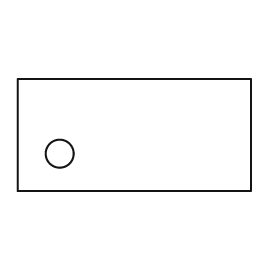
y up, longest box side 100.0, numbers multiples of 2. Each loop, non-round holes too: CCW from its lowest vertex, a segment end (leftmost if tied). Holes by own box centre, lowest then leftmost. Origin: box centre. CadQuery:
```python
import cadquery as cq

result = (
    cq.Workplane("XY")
    .moveTo(-50.0, -24.0)
    .lineTo(50.0, -24.0)
    .lineTo(50.0, 24.0)
    .lineTo(-50.0, 24.0)
    .close()
    .moveTo(-32.0, -8.0)
    .circle(6.0)
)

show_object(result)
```